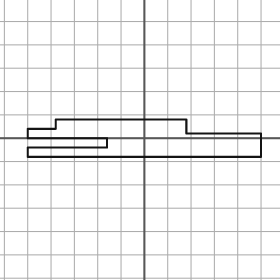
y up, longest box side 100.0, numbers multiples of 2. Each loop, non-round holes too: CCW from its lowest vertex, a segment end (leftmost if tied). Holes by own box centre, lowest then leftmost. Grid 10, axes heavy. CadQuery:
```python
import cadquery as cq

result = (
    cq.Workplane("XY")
    .moveTo(-50.0, -8.0)
    .lineTo(50.0, -8.0)
    .lineTo(50.0, 2.0)
    .lineTo(18.0, 2.0)
    .lineTo(18.0, 8.0)
    .lineTo(-38.0, 8.0)
    .lineTo(-38.0, 4.0)
    .lineTo(-50.0, 4.0)
    .lineTo(-50.0, 0.0)
    .lineTo(-16.0, 0.0)
    .lineTo(-16.0, -4.0)
    .lineTo(-50.0, -4.0)
    .close()
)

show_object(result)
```